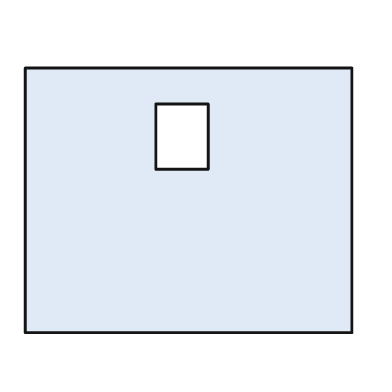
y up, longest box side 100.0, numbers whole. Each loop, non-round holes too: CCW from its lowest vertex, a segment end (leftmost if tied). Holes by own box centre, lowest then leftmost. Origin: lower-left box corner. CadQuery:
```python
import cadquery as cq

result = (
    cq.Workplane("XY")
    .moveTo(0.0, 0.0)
    .lineTo(100.0, 0.0)
    .lineTo(100.0, 81.0)
    .lineTo(0.0, 81.0)
    .close()
    .moveTo(40.0, 50.0)
    .lineTo(56.0, 50.0)
    .lineTo(56.0, 70.0)
    .lineTo(40.0, 70.0)
    .close()
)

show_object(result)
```